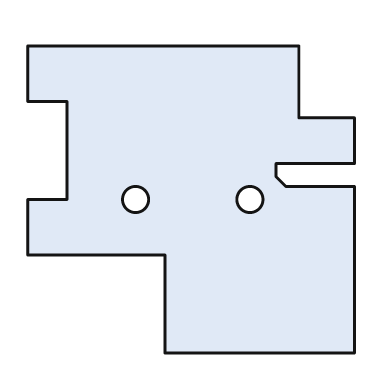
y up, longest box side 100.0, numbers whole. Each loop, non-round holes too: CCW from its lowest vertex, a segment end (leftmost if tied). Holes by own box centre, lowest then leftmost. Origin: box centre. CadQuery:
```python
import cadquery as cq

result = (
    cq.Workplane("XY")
    .moveTo(-8.0, -47.0)
    .lineTo(50.0, -47.0)
    .lineTo(50.0, 4.0)
    .lineTo(29.0, 4.0)
    .lineTo(26.0, 7.0)
    .lineTo(26.0, 11.0)
    .lineTo(50.0, 11.0)
    .lineTo(50.0, 25.0)
    .lineTo(33.0, 25.0)
    .lineTo(33.0, 47.0)
    .lineTo(-50.0, 47.0)
    .lineTo(-50.0, 30.0)
    .lineTo(-38.0, 30.0)
    .lineTo(-38.0, 0.0)
    .lineTo(-50.0, 0.0)
    .lineTo(-50.0, -17.0)
    .lineTo(-8.0, -17.0)
    .close()
    .moveTo(-17.0, 0.0)
    .circle(4.0)
    .moveTo(18.0, 0.0)
    .circle(4.0)
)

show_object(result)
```